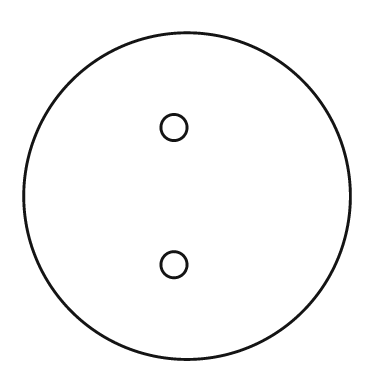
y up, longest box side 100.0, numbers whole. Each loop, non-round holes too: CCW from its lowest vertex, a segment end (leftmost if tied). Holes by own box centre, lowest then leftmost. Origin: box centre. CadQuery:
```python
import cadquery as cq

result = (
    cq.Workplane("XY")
    .moveTo(0.0, 0.0)
    .circle(50.0)
    .moveTo(-4.0, -21.0)
    .circle(4.0)
    .moveTo(-4.0, 21.0)
    .circle(4.0)
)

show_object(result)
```